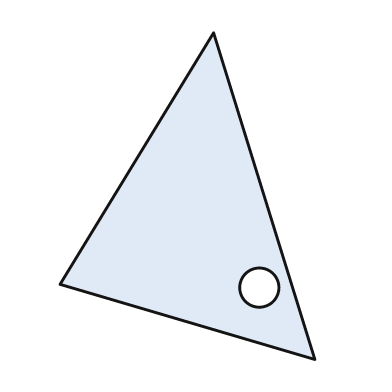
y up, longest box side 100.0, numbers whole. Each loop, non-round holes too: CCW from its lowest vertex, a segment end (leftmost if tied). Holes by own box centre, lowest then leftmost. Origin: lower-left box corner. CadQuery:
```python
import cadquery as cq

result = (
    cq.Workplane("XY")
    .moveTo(78.0, 0.0)
    .lineTo(47.0, 100.0)
    .lineTo(0.0, 23.0)
    .close()
    .moveTo(61.0, 22.0)
    .circle(6.0)
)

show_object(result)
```